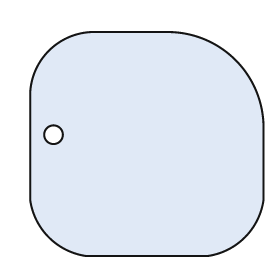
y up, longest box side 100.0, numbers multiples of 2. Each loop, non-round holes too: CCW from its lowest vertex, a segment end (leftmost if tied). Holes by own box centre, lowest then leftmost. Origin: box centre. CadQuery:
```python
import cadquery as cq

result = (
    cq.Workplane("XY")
    .moveTo(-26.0, -48.0)
    .lineTo(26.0, -48.0)
    .threePointArc((42.0, -40.0), (50.0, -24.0))
    .lineTo(50.0, 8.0)
    .threePointArc((38.0, 36.0), (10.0, 48.0))
    .lineTo(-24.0, 48.0)
    .threePointArc((-42.0, 40.0), (-50.0, 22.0))
    .lineTo(-50.0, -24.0)
    .threePointArc((-42.0, -40.0), (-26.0, -48.0))
    .close()
    .moveTo(-40.0, 4.0)
    .circle(4.0)
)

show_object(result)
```